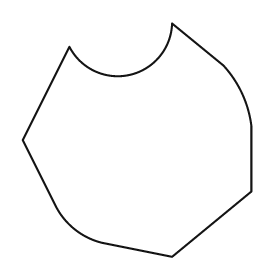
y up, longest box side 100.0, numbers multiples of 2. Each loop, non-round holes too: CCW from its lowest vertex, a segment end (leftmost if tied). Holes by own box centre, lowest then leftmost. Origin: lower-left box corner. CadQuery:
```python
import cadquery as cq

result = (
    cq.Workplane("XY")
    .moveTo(64.0, 0.0)
    .lineTo(98.0, 28.0)
    .lineTo(98.0, 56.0)
    .threePointArc((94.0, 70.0), (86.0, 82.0))
    .lineTo(64.0, 100.0)
    .threePointArc((46.0, 78.0), (20.0, 90.0))
    .lineTo(0.0, 50.0)
    .lineTo(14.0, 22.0)
    .threePointArc((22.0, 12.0), (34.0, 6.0))
    .close()
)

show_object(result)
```